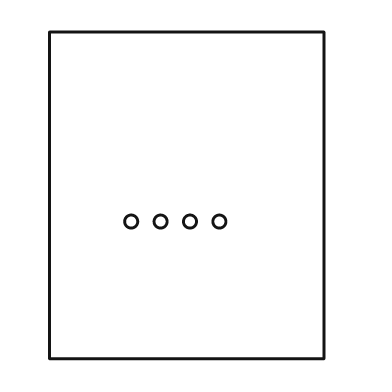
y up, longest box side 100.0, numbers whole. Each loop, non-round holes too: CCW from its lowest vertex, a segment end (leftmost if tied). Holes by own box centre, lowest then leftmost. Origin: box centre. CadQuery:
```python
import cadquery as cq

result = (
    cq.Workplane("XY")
    .moveTo(-42.0, -50.0)
    .lineTo(42.0, -50.0)
    .lineTo(42.0, 50.0)
    .lineTo(-42.0, 50.0)
    .close()
    .moveTo(-17.0, -8.0)
    .circle(2.0)
    .moveTo(-8.0, -8.0)
    .circle(2.0)
    .moveTo(1.0, -8.0)
    .circle(2.0)
    .moveTo(10.0, -8.0)
    .circle(2.0)
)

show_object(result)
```